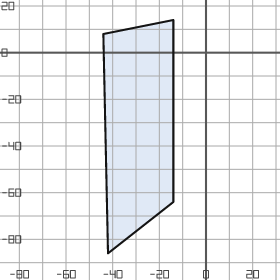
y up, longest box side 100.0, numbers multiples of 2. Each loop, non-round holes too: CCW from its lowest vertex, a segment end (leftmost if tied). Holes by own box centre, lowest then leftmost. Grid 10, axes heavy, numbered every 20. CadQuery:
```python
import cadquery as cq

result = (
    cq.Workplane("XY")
    .moveTo(-42.0, -86.0)
    .lineTo(-14.0, -64.0)
    .lineTo(-14.0, 14.0)
    .lineTo(-44.0, 8.0)
    .close()
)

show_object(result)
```